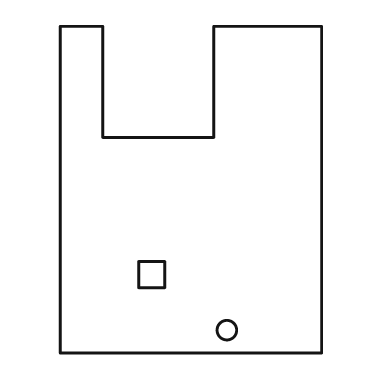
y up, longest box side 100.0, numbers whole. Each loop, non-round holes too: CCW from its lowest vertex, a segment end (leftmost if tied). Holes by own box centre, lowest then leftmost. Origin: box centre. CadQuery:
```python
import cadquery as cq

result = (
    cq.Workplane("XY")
    .moveTo(-40.0, -50.0)
    .lineTo(40.0, -50.0)
    .lineTo(40.0, 50.0)
    .lineTo(7.0, 50.0)
    .lineTo(7.0, 16.0)
    .lineTo(-27.0, 16.0)
    .lineTo(-27.0, 50.0)
    .lineTo(-40.0, 50.0)
    .close()
    .moveTo(11.0, -43.0)
    .circle(3.0)
    .moveTo(-16.0, -30.0)
    .lineTo(-8.0, -30.0)
    .lineTo(-8.0, -22.0)
    .lineTo(-16.0, -22.0)
    .close()
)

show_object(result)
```